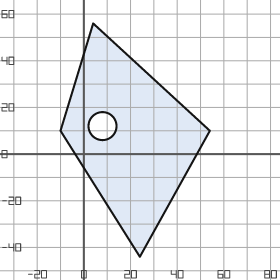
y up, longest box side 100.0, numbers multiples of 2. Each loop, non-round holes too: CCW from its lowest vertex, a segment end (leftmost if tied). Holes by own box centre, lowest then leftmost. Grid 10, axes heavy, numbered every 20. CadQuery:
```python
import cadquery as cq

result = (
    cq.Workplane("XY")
    .moveTo(24.0, -44.0)
    .lineTo(54.0, 10.0)
    .lineTo(4.0, 56.0)
    .lineTo(-10.0, 10.0)
    .close()
    .moveTo(8.0, 12.0)
    .circle(6.0)
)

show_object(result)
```